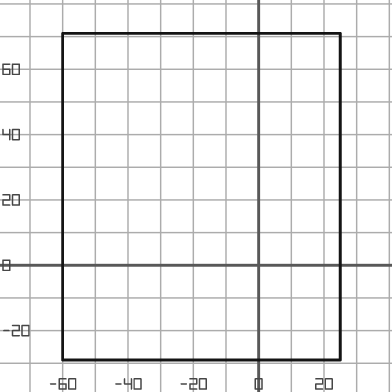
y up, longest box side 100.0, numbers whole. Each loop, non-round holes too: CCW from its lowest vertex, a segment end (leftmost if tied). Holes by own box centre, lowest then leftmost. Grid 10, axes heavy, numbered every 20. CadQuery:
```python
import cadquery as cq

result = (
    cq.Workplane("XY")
    .moveTo(-60.0, -29.0)
    .lineTo(25.0, -29.0)
    .lineTo(25.0, 71.0)
    .lineTo(-60.0, 71.0)
    .close()
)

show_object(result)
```